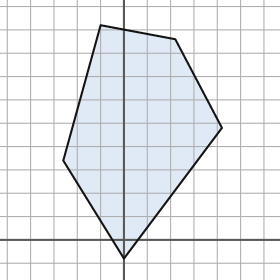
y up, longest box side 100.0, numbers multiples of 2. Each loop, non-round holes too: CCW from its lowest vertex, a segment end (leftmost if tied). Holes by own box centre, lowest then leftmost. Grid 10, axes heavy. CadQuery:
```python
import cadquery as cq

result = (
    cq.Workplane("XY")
    .moveTo(0.0, -8.0)
    .lineTo(42.0, 48.0)
    .lineTo(22.0, 86.0)
    .lineTo(-10.0, 92.0)
    .lineTo(-26.0, 34.0)
    .close()
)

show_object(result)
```